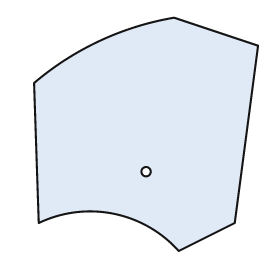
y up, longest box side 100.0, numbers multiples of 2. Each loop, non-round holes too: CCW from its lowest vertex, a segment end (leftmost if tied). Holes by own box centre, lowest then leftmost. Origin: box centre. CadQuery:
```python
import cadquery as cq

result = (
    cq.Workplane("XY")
    .moveTo(14.0, -50.0)
    .lineTo(38.0, -38.0)
    .lineTo(48.0, 38.0)
    .lineTo(12.0, 50.0)
    .threePointArc((-20.0, 40.0), (-48.0, 22.0))
    .lineTo(-46.0, -38.0)
    .threePointArc((-14.0, -34.0), (14.0, -50.0))
    .close()
    .moveTo(0.0, -16.0)
    .circle(2.0)
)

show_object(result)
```